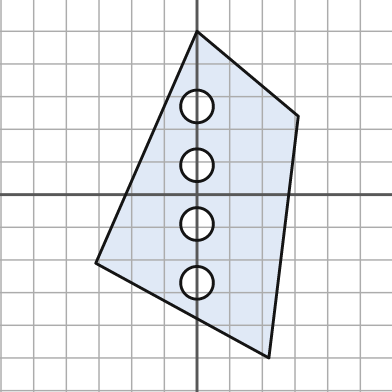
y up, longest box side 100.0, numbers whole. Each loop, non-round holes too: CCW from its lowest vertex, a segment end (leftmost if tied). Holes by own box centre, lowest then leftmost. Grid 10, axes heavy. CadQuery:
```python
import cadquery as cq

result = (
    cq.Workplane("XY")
    .moveTo(22.0, -50.0)
    .lineTo(31.0, 24.0)
    .lineTo(0.0, 50.0)
    .lineTo(-31.0, -21.0)
    .close()
    .moveTo(0.0, -27.0)
    .circle(5.0)
    .moveTo(0.0, -9.0)
    .circle(5.0)
    .moveTo(0.0, 9.0)
    .circle(5.0)
    .moveTo(0.0, 27.0)
    .circle(5.0)
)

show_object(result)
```